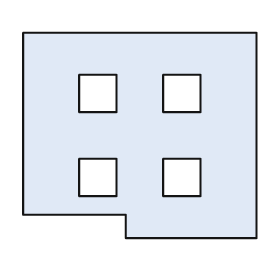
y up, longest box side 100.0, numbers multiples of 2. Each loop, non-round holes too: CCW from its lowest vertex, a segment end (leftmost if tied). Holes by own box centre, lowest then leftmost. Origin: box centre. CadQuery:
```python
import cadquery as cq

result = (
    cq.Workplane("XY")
    .moveTo(-6.0, -44.0)
    .lineTo(50.0, -44.0)
    .lineTo(50.0, 44.0)
    .lineTo(-50.0, 44.0)
    .lineTo(-50.0, -34.0)
    .lineTo(-6.0, -34.0)
    .close()
    .moveTo(-26.0, -26.0)
    .lineTo(-10.0, -26.0)
    .lineTo(-10.0, -10.0)
    .lineTo(-26.0, -10.0)
    .close()
    .moveTo(10.0, -26.0)
    .lineTo(26.0, -26.0)
    .lineTo(26.0, -10.0)
    .lineTo(10.0, -10.0)
    .close()
    .moveTo(-26.0, 10.0)
    .lineTo(-10.0, 10.0)
    .lineTo(-10.0, 26.0)
    .lineTo(-26.0, 26.0)
    .close()
    .moveTo(10.0, 10.0)
    .lineTo(26.0, 10.0)
    .lineTo(26.0, 26.0)
    .lineTo(10.0, 26.0)
    .close()
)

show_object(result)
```